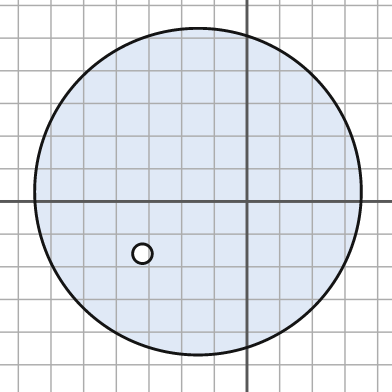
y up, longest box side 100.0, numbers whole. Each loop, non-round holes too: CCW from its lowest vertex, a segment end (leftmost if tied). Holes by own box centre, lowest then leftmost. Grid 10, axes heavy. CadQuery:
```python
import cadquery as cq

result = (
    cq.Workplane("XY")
    .moveTo(-15.0, 3.0)
    .circle(50.0)
    .moveTo(-32.0, -16.0)
    .circle(3.0)
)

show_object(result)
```